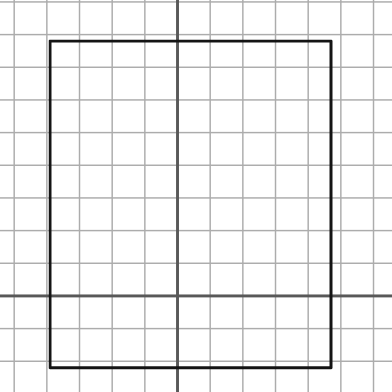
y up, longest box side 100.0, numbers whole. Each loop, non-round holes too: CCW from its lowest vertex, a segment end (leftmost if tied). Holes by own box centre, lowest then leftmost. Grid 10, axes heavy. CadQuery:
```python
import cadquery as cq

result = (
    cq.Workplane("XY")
    .moveTo(-39.0, -22.0)
    .lineTo(47.0, -22.0)
    .lineTo(47.0, 78.0)
    .lineTo(-39.0, 78.0)
    .close()
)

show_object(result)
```